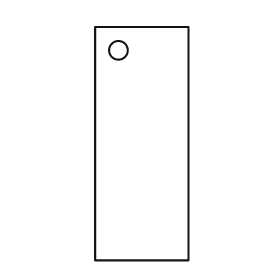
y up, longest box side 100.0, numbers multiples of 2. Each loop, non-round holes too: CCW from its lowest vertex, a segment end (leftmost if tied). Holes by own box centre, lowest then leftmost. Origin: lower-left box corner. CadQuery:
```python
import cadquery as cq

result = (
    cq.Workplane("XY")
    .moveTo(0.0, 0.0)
    .lineTo(40.0, 0.0)
    .lineTo(40.0, 100.0)
    .lineTo(0.0, 100.0)
    .close()
    .moveTo(10.0, 90.0)
    .circle(4.0)
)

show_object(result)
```